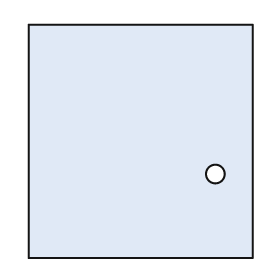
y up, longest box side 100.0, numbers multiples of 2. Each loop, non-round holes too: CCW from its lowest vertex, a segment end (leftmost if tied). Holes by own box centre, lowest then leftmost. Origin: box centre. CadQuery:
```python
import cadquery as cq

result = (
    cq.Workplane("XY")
    .moveTo(-48.0, -50.0)
    .lineTo(48.0, -50.0)
    .lineTo(48.0, 50.0)
    .lineTo(-48.0, 50.0)
    .close()
    .moveTo(32.0, -14.0)
    .circle(4.0)
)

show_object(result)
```